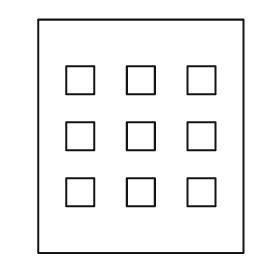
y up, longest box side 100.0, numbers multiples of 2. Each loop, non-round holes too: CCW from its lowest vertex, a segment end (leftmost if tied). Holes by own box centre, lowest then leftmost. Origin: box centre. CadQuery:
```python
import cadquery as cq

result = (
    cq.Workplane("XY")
    .moveTo(-44.0, -50.0)
    .lineTo(44.0, -50.0)
    .lineTo(44.0, 50.0)
    .lineTo(-44.0, 50.0)
    .close()
    .moveTo(-32.0, -30.0)
    .lineTo(-20.0, -30.0)
    .lineTo(-20.0, -18.0)
    .lineTo(-32.0, -18.0)
    .close()
    .moveTo(-6.0, -30.0)
    .lineTo(6.0, -30.0)
    .lineTo(6.0, -18.0)
    .lineTo(-6.0, -18.0)
    .close()
    .moveTo(20.0, -30.0)
    .lineTo(32.0, -30.0)
    .lineTo(32.0, -18.0)
    .lineTo(20.0, -18.0)
    .close()
    .moveTo(-32.0, -6.0)
    .lineTo(-20.0, -6.0)
    .lineTo(-20.0, 6.0)
    .lineTo(-32.0, 6.0)
    .close()
    .moveTo(-6.0, -6.0)
    .lineTo(6.0, -6.0)
    .lineTo(6.0, 6.0)
    .lineTo(-6.0, 6.0)
    .close()
    .moveTo(20.0, -6.0)
    .lineTo(32.0, -6.0)
    .lineTo(32.0, 6.0)
    .lineTo(20.0, 6.0)
    .close()
    .moveTo(-32.0, 18.0)
    .lineTo(-20.0, 18.0)
    .lineTo(-20.0, 30.0)
    .lineTo(-32.0, 30.0)
    .close()
    .moveTo(-6.0, 18.0)
    .lineTo(6.0, 18.0)
    .lineTo(6.0, 30.0)
    .lineTo(-6.0, 30.0)
    .close()
    .moveTo(20.0, 18.0)
    .lineTo(32.0, 18.0)
    .lineTo(32.0, 30.0)
    .lineTo(20.0, 30.0)
    .close()
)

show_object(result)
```